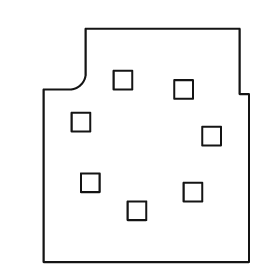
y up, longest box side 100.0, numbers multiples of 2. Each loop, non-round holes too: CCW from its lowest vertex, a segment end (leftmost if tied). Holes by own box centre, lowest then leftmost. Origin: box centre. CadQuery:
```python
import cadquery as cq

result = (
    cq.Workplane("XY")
    .moveTo(-44.0, -50.0)
    .lineTo(44.0, -50.0)
    .lineTo(44.0, 22.0)
    .lineTo(40.0, 22.0)
    .lineTo(40.0, 50.0)
    .lineTo(-26.0, 50.0)
    .lineTo(-26.0, 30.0)
    .threePointArc((-28.0, 26.0), (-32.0, 24.0))
    .lineTo(-44.0, 24.0)
    .close()
    .moveTo(-8.0, -32.0)
    .lineTo(0.0, -32.0)
    .lineTo(0.0, -24.0)
    .lineTo(-8.0, -24.0)
    .close()
    .moveTo(16.0, -24.0)
    .lineTo(24.0, -24.0)
    .lineTo(24.0, -16.0)
    .lineTo(16.0, -16.0)
    .close()
    .moveTo(-28.0, -20.0)
    .lineTo(-20.0, -20.0)
    .lineTo(-20.0, -12.0)
    .lineTo(-28.0, -12.0)
    .close()
    .moveTo(24.0, 0.0)
    .lineTo(32.0, 0.0)
    .lineTo(32.0, 8.0)
    .lineTo(24.0, 8.0)
    .close()
    .moveTo(-32.0, 6.0)
    .lineTo(-24.0, 6.0)
    .lineTo(-24.0, 14.0)
    .lineTo(-32.0, 14.0)
    .close()
    .moveTo(12.0, 20.0)
    .lineTo(20.0, 20.0)
    .lineTo(20.0, 28.0)
    .lineTo(12.0, 28.0)
    .close()
    .moveTo(-14.0, 24.0)
    .lineTo(-6.0, 24.0)
    .lineTo(-6.0, 32.0)
    .lineTo(-14.0, 32.0)
    .close()
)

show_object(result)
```